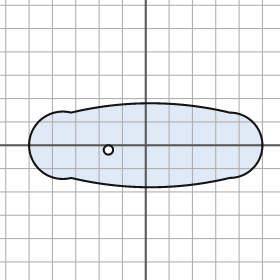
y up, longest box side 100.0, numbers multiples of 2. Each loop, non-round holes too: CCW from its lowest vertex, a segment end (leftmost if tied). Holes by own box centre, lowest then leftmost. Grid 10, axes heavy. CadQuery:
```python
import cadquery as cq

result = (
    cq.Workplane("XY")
    .moveTo(-32.0, -14.0)
    .threePointArc((2.0, -18.0), (36.0, -14.0))
    .threePointArc((50.0, 0.0), (36.0, 14.0))
    .threePointArc((2.0, 18.0), (-32.0, 14.0))
    .threePointArc((-50.0, 0.0), (-32.0, -14.0))
    .close()
    .moveTo(-16.0, -2.0)
    .circle(2.0)
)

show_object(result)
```